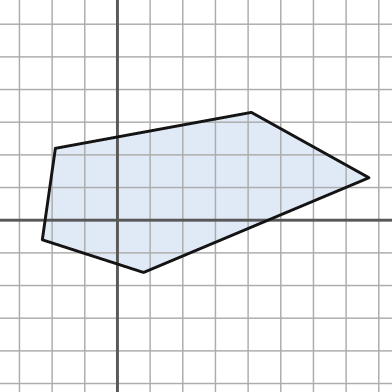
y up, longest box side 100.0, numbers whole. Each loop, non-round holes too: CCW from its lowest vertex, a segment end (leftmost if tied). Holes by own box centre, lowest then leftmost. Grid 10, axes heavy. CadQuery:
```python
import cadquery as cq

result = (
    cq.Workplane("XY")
    .moveTo(8.0, -16.0)
    .lineTo(77.0, 13.0)
    .lineTo(41.0, 33.0)
    .lineTo(-19.0, 22.0)
    .lineTo(-23.0, -6.0)
    .close()
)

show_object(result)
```